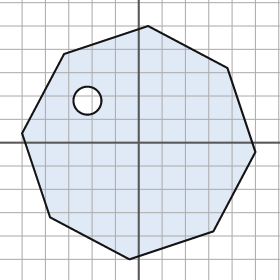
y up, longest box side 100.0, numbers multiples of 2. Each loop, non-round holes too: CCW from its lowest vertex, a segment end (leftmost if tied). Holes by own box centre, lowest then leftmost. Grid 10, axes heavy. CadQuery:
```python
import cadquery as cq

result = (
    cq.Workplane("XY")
    .moveTo(-4.0, -50.0)
    .lineTo(32.0, -38.0)
    .lineTo(50.0, -4.0)
    .lineTo(38.0, 32.0)
    .lineTo(4.0, 50.0)
    .lineTo(-32.0, 38.0)
    .lineTo(-50.0, 4.0)
    .lineTo(-38.0, -32.0)
    .close()
    .moveTo(-22.0, 18.0)
    .circle(6.0)
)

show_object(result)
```